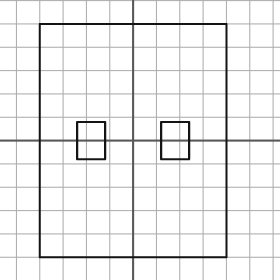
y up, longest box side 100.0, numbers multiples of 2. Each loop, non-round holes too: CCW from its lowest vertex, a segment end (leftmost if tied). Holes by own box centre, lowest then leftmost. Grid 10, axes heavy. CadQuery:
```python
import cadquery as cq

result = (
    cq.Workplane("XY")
    .moveTo(-40.0, -50.0)
    .lineTo(40.0, -50.0)
    .lineTo(40.0, 50.0)
    .lineTo(-40.0, 50.0)
    .close()
    .moveTo(-24.0, -8.0)
    .lineTo(-12.0, -8.0)
    .lineTo(-12.0, 8.0)
    .lineTo(-24.0, 8.0)
    .close()
    .moveTo(12.0, -8.0)
    .lineTo(24.0, -8.0)
    .lineTo(24.0, 8.0)
    .lineTo(12.0, 8.0)
    .close()
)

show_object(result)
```